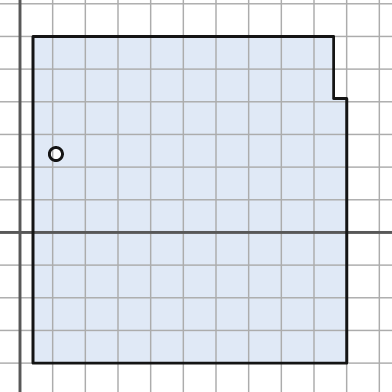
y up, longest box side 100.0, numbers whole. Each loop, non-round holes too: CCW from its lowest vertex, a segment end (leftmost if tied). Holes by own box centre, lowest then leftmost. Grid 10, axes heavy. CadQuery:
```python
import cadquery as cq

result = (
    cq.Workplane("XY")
    .moveTo(4.0, -40.0)
    .lineTo(100.0, -40.0)
    .lineTo(100.0, 41.0)
    .lineTo(96.0, 41.0)
    .lineTo(96.0, 60.0)
    .lineTo(4.0, 60.0)
    .close()
    .moveTo(11.0, 24.0)
    .circle(2.0)
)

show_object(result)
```